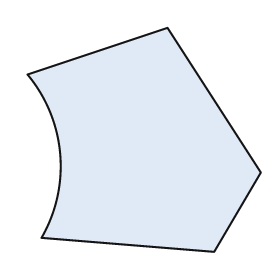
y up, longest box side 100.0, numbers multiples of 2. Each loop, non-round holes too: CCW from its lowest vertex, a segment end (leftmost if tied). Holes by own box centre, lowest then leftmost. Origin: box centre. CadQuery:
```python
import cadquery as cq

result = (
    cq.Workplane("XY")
    .moveTo(30.0, -48.0)
    .lineTo(50.0, -14.0)
    .lineTo(10.0, 48.0)
    .lineTo(-50.0, 28.0)
    .threePointArc((-36.0, -6.0), (-44.0, -42.0))
    .close()
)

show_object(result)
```